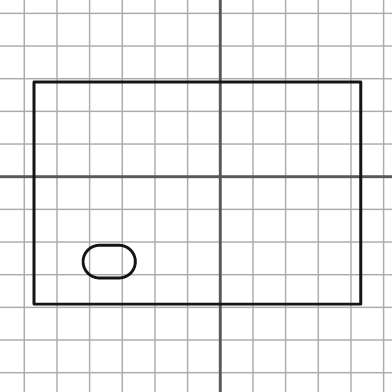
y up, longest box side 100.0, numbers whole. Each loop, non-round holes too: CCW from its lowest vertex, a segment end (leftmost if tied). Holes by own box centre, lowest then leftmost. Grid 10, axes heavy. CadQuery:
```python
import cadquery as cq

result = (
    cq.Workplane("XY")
    .moveTo(-57.0, -39.0)
    .lineTo(43.0, -39.0)
    .lineTo(43.0, 29.0)
    .lineTo(-57.0, 29.0)
    .close()
    .moveTo(-37.0, -31.0)
    .lineTo(-31.0, -31.0)
    .threePointArc((-26.0, -26.0), (-31.0, -21.0))
    .lineTo(-37.0, -21.0)
    .threePointArc((-42.0, -26.0), (-37.0, -31.0))
    .close()
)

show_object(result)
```